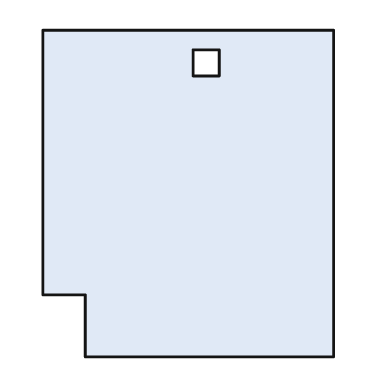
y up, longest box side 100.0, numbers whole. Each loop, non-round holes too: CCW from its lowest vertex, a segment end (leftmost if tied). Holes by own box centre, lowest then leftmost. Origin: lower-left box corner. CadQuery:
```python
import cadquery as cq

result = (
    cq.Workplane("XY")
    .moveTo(13.0, 0.0)
    .lineTo(89.0, 0.0)
    .lineTo(89.0, 100.0)
    .lineTo(0.0, 100.0)
    .lineTo(0.0, 19.0)
    .lineTo(13.0, 19.0)
    .close()
    .moveTo(46.0, 86.0)
    .lineTo(54.0, 86.0)
    .lineTo(54.0, 94.0)
    .lineTo(46.0, 94.0)
    .close()
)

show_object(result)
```